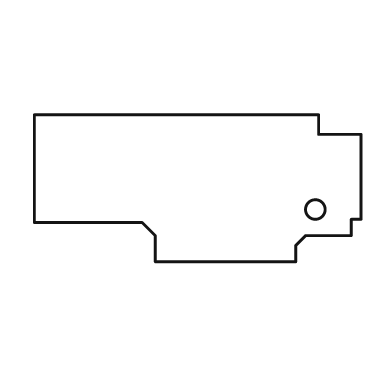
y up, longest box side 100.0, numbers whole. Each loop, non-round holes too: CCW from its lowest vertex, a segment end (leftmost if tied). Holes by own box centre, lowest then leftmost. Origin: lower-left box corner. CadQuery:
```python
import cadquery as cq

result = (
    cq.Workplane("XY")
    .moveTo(37.0, 0.0)
    .lineTo(80.0, 0.0)
    .lineTo(80.0, 5.0)
    .lineTo(83.0, 8.0)
    .lineTo(97.0, 8.0)
    .lineTo(97.0, 13.0)
    .lineTo(100.0, 13.0)
    .lineTo(100.0, 39.0)
    .lineTo(87.0, 39.0)
    .lineTo(87.0, 45.0)
    .lineTo(0.0, 45.0)
    .lineTo(0.0, 12.0)
    .lineTo(33.0, 12.0)
    .lineTo(37.0, 8.0)
    .close()
    .moveTo(86.0, 16.0)
    .circle(3.0)
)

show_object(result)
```